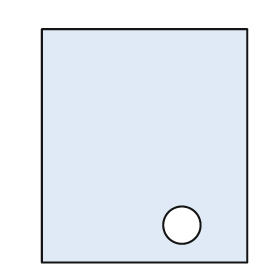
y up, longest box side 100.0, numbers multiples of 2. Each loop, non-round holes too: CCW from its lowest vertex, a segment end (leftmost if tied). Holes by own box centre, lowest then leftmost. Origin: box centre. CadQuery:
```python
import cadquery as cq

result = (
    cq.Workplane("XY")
    .moveTo(-44.0, -50.0)
    .lineTo(44.0, -50.0)
    .lineTo(44.0, 50.0)
    .lineTo(-44.0, 50.0)
    .close()
    .moveTo(16.0, -34.0)
    .circle(8.0)
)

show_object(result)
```